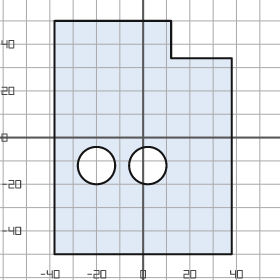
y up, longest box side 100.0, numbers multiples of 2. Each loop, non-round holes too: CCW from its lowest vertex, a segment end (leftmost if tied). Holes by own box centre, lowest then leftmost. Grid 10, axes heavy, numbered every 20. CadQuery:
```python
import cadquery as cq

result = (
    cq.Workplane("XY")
    .moveTo(-38.0, -50.0)
    .lineTo(38.0, -50.0)
    .lineTo(38.0, 34.0)
    .lineTo(12.0, 34.0)
    .lineTo(12.0, 50.0)
    .lineTo(-38.0, 50.0)
    .close()
    .moveTo(-20.0, -12.0)
    .circle(8.0)
    .moveTo(2.0, -12.0)
    .circle(8.0)
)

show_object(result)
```